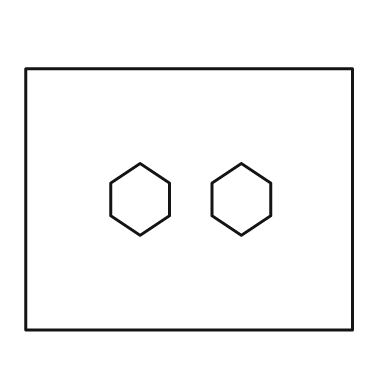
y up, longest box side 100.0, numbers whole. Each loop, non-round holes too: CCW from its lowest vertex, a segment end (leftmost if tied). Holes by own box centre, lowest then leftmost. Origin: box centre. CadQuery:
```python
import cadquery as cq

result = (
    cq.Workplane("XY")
    .moveTo(-50.0, -40.0)
    .lineTo(50.0, -40.0)
    .lineTo(50.0, 40.0)
    .lineTo(-50.0, 40.0)
    .close()
    .moveTo(-15.0, -11.0)
    .lineTo(-6.0, -5.0)
    .lineTo(-6.0, 5.0)
    .lineTo(-15.0, 11.0)
    .lineTo(-24.0, 5.0)
    .lineTo(-24.0, -5.0)
    .close()
    .moveTo(16.0, -11.0)
    .lineTo(25.0, -5.0)
    .lineTo(25.0, 5.0)
    .lineTo(16.0, 11.0)
    .lineTo(7.0, 5.0)
    .lineTo(7.0, -5.0)
    .close()
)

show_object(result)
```